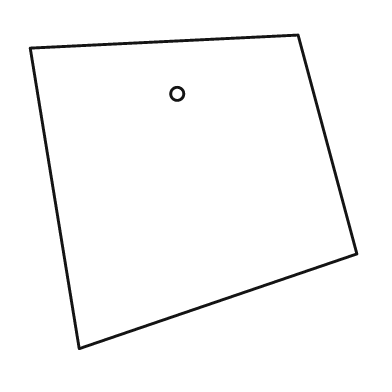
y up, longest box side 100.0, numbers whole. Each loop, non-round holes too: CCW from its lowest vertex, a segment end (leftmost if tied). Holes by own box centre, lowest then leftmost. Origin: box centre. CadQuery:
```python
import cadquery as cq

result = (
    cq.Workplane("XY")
    .moveTo(-35.0, -48.0)
    .lineTo(50.0, -19.0)
    .lineTo(32.0, 48.0)
    .lineTo(-50.0, 44.0)
    .close()
    .moveTo(-5.0, 30.0)
    .circle(2.0)
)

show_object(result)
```